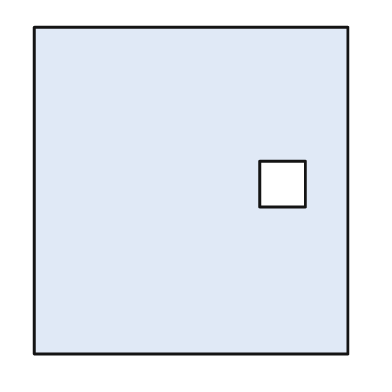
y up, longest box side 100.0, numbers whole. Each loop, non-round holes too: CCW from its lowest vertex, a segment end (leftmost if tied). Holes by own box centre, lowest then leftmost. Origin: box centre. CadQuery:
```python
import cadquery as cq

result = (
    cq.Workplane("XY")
    .moveTo(-48.0, -50.0)
    .lineTo(48.0, -50.0)
    .lineTo(48.0, 50.0)
    .lineTo(-48.0, 50.0)
    .close()
    .moveTo(21.0, -5.0)
    .lineTo(35.0, -5.0)
    .lineTo(35.0, 9.0)
    .lineTo(21.0, 9.0)
    .close()
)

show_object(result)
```